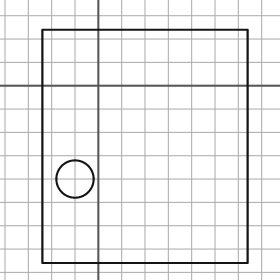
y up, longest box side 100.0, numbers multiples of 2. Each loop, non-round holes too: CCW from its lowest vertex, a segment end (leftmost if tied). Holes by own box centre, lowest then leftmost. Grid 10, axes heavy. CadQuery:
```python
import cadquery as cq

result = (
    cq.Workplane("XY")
    .moveTo(-24.0, -76.0)
    .lineTo(64.0, -76.0)
    .lineTo(64.0, 24.0)
    .lineTo(-24.0, 24.0)
    .close()
    .moveTo(-10.0, -40.0)
    .circle(8.0)
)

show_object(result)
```